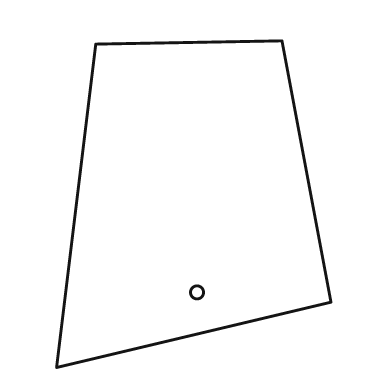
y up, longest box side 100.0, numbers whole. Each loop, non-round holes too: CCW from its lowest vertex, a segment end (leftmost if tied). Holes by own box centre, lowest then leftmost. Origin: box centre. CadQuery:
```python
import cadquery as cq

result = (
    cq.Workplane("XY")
    .moveTo(-42.0, -50.0)
    .lineTo(42.0, -30.0)
    .lineTo(27.0, 50.0)
    .lineTo(-30.0, 49.0)
    .close()
    .moveTo(1.0, -27.0)
    .circle(2.0)
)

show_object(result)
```